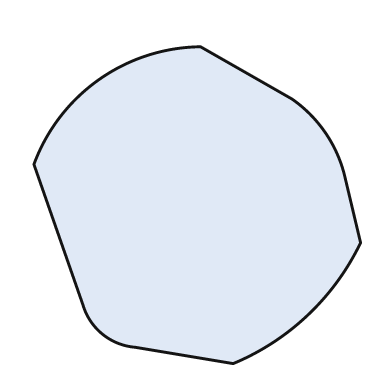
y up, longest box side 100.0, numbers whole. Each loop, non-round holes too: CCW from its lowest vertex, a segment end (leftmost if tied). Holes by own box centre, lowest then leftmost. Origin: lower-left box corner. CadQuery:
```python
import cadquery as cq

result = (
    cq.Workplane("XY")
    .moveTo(61.0, 0.0)
    .threePointArc((84.0, 15.0), (100.0, 37.0))
    .lineTo(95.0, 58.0)
    .threePointArc((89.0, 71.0), (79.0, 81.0))
    .lineTo(51.0, 97.0)
    .threePointArc((20.0, 87.0), (0.0, 61.0))
    .lineTo(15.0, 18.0)
    .threePointArc((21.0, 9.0), (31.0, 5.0))
    .close()
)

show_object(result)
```